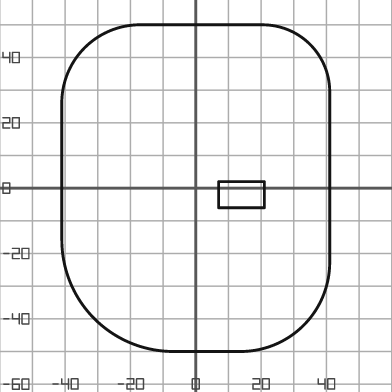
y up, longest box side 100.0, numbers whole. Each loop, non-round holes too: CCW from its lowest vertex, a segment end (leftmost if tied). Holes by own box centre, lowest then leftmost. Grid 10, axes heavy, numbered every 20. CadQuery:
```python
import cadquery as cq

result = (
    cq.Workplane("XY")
    .moveTo(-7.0, -50.0)
    .lineTo(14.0, -50.0)
    .threePointArc((33.0, -42.0), (41.0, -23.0))
    .lineTo(41.0, 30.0)
    .threePointArc((35.0, 44.0), (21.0, 50.0))
    .lineTo(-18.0, 50.0)
    .threePointArc((-34.0, 43.0), (-41.0, 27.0))
    .lineTo(-41.0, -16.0)
    .threePointArc((-31.0, -40.0), (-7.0, -50.0))
    .close()
    .moveTo(7.0, -6.0)
    .lineTo(21.0, -6.0)
    .lineTo(21.0, 2.0)
    .lineTo(7.0, 2.0)
    .close()
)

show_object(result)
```